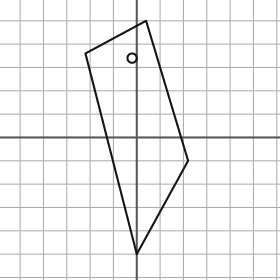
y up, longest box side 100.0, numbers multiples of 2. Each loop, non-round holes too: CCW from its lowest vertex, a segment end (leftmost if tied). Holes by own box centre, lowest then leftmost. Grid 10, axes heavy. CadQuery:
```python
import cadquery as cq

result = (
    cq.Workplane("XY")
    .moveTo(0.0, -50.0)
    .lineTo(22.0, -10.0)
    .lineTo(4.0, 50.0)
    .lineTo(-22.0, 36.0)
    .close()
    .moveTo(-2.0, 34.0)
    .circle(2.0)
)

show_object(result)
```